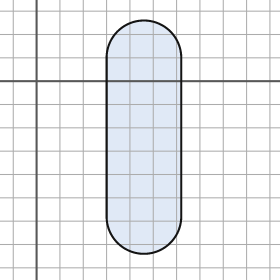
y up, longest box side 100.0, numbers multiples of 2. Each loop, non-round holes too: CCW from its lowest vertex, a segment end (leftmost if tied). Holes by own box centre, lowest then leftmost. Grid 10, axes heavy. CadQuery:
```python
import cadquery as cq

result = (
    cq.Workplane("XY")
    .moveTo(30.0, -58.0)
    .threePointArc((46.0, -74.0), (62.0, -58.0))
    .lineTo(62.0, 10.0)
    .threePointArc((46.0, 26.0), (30.0, 10.0))
    .close()
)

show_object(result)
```